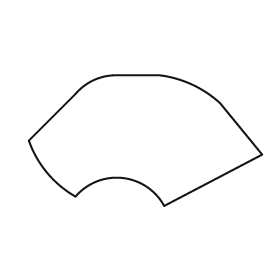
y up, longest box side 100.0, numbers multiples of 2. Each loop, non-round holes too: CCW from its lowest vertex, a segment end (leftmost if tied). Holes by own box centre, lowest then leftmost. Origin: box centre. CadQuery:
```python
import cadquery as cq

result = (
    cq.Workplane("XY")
    .moveTo(8.0, -28.0)
    .lineTo(50.0, -6.0)
    .lineTo(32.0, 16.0)
    .threePointArc((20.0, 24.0), (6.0, 28.0))
    .lineTo(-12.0, 28.0)
    .threePointArc((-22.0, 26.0), (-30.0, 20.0))
    .lineTo(-50.0, 0.0)
    .threePointArc((-42.0, -14.0), (-30.0, -24.0))
    .threePointArc((-10.0, -16.0), (8.0, -28.0))
    .close()
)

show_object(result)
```